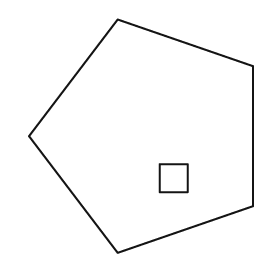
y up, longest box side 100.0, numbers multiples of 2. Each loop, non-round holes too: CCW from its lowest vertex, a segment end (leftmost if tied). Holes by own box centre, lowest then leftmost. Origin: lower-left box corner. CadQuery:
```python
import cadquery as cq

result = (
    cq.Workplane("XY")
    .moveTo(38.0, 0.0)
    .lineTo(96.0, 20.0)
    .lineTo(96.0, 80.0)
    .lineTo(38.0, 100.0)
    .lineTo(0.0, 50.0)
    .close()
    .moveTo(56.0, 26.0)
    .lineTo(68.0, 26.0)
    .lineTo(68.0, 38.0)
    .lineTo(56.0, 38.0)
    .close()
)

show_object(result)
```